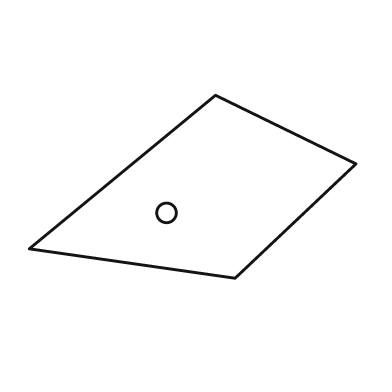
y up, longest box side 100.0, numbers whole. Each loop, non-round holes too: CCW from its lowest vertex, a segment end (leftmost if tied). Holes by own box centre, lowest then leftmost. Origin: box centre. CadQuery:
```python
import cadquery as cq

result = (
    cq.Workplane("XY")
    .moveTo(13.0, -28.0)
    .lineTo(50.0, 7.0)
    .lineTo(7.0, 28.0)
    .lineTo(-50.0, -19.0)
    .close()
    .moveTo(-8.0, -8.0)
    .circle(3.0)
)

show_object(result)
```